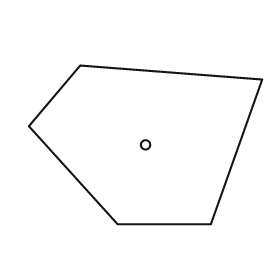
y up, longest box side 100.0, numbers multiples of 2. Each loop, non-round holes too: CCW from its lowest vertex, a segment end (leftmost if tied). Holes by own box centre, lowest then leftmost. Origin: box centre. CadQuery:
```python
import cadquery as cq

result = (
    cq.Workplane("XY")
    .moveTo(-12.0, -34.0)
    .lineTo(28.0, -34.0)
    .lineTo(50.0, 28.0)
    .lineTo(-28.0, 34.0)
    .lineTo(-50.0, 8.0)
    .close()
    .moveTo(0.0, 0.0)
    .circle(2.0)
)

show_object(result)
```